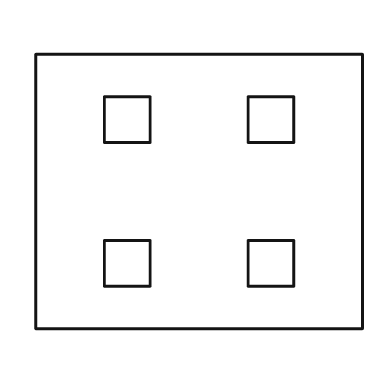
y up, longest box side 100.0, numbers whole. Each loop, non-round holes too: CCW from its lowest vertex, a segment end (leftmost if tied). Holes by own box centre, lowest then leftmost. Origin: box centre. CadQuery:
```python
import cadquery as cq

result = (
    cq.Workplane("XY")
    .moveTo(-50.0, -42.0)
    .lineTo(50.0, -42.0)
    .lineTo(50.0, 42.0)
    .lineTo(-50.0, 42.0)
    .close()
    .moveTo(-29.0, -29.0)
    .lineTo(-15.0, -29.0)
    .lineTo(-15.0, -15.0)
    .lineTo(-29.0, -15.0)
    .close()
    .moveTo(15.0, -29.0)
    .lineTo(29.0, -29.0)
    .lineTo(29.0, -15.0)
    .lineTo(15.0, -15.0)
    .close()
    .moveTo(-29.0, 15.0)
    .lineTo(-15.0, 15.0)
    .lineTo(-15.0, 29.0)
    .lineTo(-29.0, 29.0)
    .close()
    .moveTo(15.0, 15.0)
    .lineTo(29.0, 15.0)
    .lineTo(29.0, 29.0)
    .lineTo(15.0, 29.0)
    .close()
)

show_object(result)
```